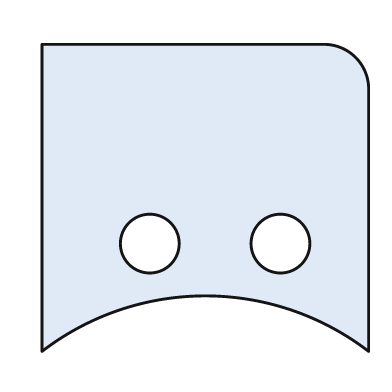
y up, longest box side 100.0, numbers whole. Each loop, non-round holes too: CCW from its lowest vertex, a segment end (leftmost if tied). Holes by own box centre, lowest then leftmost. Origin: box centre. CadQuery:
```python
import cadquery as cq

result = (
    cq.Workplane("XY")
    .moveTo(-50.0, -47.0)
    .threePointArc((0.0, -30.0), (50.0, -47.0))
    .lineTo(50.0, 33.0)
    .threePointArc((46.0, 43.0), (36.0, 47.0))
    .lineTo(-50.0, 47.0)
    .close()
    .moveTo(-17.0, -14.0)
    .circle(9.0)
    .moveTo(23.0, -14.0)
    .circle(9.0)
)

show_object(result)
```